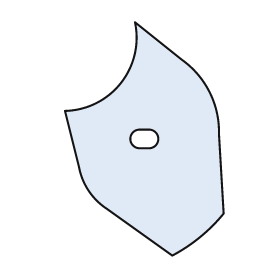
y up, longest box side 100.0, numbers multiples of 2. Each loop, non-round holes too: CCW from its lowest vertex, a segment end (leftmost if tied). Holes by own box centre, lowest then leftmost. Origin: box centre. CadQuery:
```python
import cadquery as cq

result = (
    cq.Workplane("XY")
    .moveTo(12.0, -50.0)
    .threePointArc((24.0, -42.0), (34.0, -32.0))
    .lineTo(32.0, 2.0)
    .threePointArc((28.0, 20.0), (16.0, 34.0))
    .lineTo(-4.0, 50.0)
    .threePointArc((-10.0, 24.0), (-34.0, 12.0))
    .lineTo(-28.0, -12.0)
    .threePointArc((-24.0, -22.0), (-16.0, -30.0))
    .close()
    .moveTo(-2.0, -4.0)
    .lineTo(2.0, -4.0)
    .threePointArc((6.0, 0.0), (2.0, 4.0))
    .lineTo(-2.0, 4.0)
    .threePointArc((-6.0, 0.0), (-2.0, -4.0))
    .close()
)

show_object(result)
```